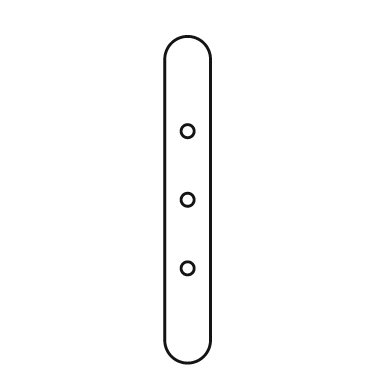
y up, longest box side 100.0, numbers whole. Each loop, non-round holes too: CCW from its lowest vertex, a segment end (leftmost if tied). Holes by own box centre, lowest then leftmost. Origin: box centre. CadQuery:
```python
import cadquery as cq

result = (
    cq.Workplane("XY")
    .moveTo(-7.0, -43.0)
    .threePointArc((0.0, -50.0), (7.0, -43.0))
    .lineTo(7.0, 43.0)
    .threePointArc((0.0, 50.0), (-7.0, 43.0))
    .close()
    .moveTo(0.0, -21.0)
    .circle(2.0)
    .moveTo(0.0, 0.0)
    .circle(2.0)
    .moveTo(0.0, 21.0)
    .circle(2.0)
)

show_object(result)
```